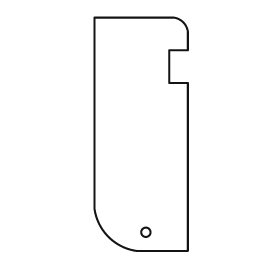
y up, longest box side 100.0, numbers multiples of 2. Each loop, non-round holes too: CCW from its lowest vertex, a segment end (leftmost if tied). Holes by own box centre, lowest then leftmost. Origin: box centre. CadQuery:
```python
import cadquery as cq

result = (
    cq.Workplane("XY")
    .moveTo(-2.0, -50.0)
    .lineTo(20.0, -50.0)
    .lineTo(20.0, 22.0)
    .lineTo(12.0, 22.0)
    .lineTo(12.0, 36.0)
    .lineTo(20.0, 36.0)
    .lineTo(20.0, 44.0)
    .threePointArc((18.0, 48.0), (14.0, 50.0))
    .lineTo(-20.0, 50.0)
    .lineTo(-20.0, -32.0)
    .threePointArc((-14.0, -44.0), (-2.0, -50.0))
    .close()
    .moveTo(2.0, -42.0)
    .circle(2.0)
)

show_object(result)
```